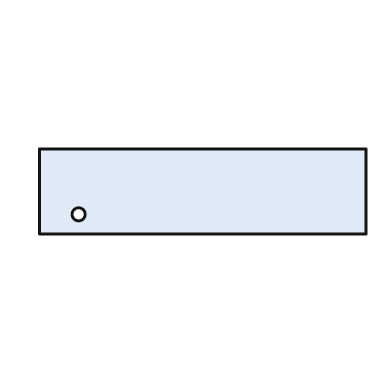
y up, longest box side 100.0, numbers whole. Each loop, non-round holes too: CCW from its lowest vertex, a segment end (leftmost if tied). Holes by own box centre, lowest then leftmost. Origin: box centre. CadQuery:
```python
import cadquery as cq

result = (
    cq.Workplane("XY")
    .moveTo(-50.0, -13.0)
    .lineTo(50.0, -13.0)
    .lineTo(50.0, 13.0)
    .lineTo(-50.0, 13.0)
    .close()
    .moveTo(-38.0, -7.0)
    .circle(2.0)
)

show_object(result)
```